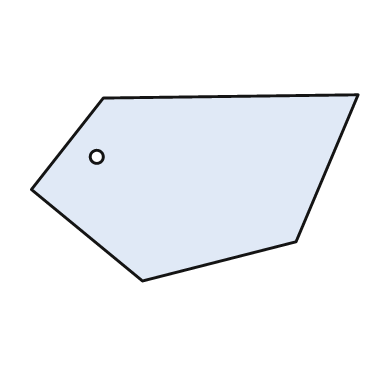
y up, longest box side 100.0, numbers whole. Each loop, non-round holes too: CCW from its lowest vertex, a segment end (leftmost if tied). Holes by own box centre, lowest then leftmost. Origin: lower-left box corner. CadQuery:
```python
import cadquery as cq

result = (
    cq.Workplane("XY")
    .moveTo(34.0, 0.0)
    .lineTo(81.0, 12.0)
    .lineTo(100.0, 57.0)
    .lineTo(22.0, 56.0)
    .lineTo(0.0, 28.0)
    .close()
    .moveTo(20.0, 38.0)
    .circle(2.0)
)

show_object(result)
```